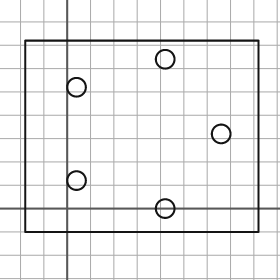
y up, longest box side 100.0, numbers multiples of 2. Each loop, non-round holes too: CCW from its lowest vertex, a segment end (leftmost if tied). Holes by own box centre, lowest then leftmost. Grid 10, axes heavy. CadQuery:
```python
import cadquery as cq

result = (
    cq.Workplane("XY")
    .moveTo(-18.0, -10.0)
    .lineTo(82.0, -10.0)
    .lineTo(82.0, 72.0)
    .lineTo(-18.0, 72.0)
    .close()
    .moveTo(42.0, 0.0)
    .circle(4.0)
    .moveTo(4.0, 12.0)
    .circle(4.0)
    .moveTo(66.0, 32.0)
    .circle(4.0)
    .moveTo(4.0, 52.0)
    .circle(4.0)
    .moveTo(42.0, 64.0)
    .circle(4.0)
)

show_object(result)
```